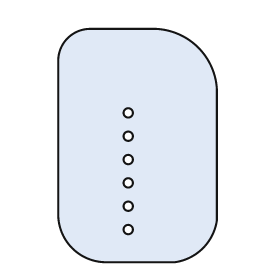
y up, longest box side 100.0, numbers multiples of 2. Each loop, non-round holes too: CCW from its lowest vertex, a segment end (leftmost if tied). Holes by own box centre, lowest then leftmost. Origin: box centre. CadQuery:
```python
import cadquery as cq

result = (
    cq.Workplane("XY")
    .moveTo(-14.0, -50.0)
    .lineTo(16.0, -50.0)
    .threePointArc((28.0, -44.0), (34.0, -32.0))
    .lineTo(34.0, 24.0)
    .threePointArc((26.0, 42.0), (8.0, 50.0))
    .lineTo(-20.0, 50.0)
    .threePointArc((-30.0, 46.0), (-34.0, 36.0))
    .lineTo(-34.0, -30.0)
    .threePointArc((-28.0, -44.0), (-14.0, -50.0))
    .close()
    .moveTo(-4.0, -36.0)
    .circle(2.0)
    .moveTo(-4.0, -26.0)
    .circle(2.0)
    .moveTo(-4.0, -16.0)
    .circle(2.0)
    .moveTo(-4.0, -6.0)
    .circle(2.0)
    .moveTo(-4.0, 4.0)
    .circle(2.0)
    .moveTo(-4.0, 14.0)
    .circle(2.0)
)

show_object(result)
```